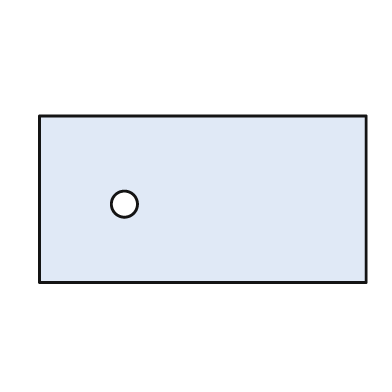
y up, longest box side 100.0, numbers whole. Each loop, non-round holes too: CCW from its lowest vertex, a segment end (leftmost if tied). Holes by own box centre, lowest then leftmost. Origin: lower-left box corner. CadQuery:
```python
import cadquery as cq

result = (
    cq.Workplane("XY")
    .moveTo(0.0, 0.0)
    .lineTo(100.0, 0.0)
    .lineTo(100.0, 51.0)
    .lineTo(0.0, 51.0)
    .close()
    .moveTo(26.0, 24.0)
    .circle(4.0)
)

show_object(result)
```